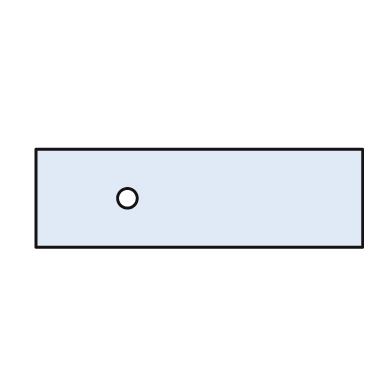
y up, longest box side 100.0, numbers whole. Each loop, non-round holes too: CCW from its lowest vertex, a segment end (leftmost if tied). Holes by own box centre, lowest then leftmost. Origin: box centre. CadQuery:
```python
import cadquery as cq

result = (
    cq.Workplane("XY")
    .moveTo(-50.0, -15.0)
    .lineTo(50.0, -15.0)
    .lineTo(50.0, 15.0)
    .lineTo(-50.0, 15.0)
    .close()
    .moveTo(-22.0, 0.0)
    .circle(3.0)
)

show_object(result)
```